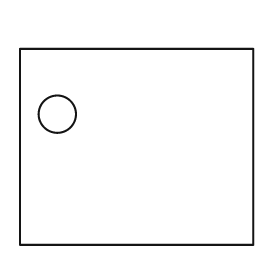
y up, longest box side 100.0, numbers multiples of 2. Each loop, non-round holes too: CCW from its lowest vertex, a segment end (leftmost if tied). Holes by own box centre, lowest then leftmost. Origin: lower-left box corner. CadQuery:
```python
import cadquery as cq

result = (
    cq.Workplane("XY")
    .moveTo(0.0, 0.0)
    .lineTo(100.0, 0.0)
    .lineTo(100.0, 84.0)
    .lineTo(0.0, 84.0)
    .close()
    .moveTo(16.0, 56.0)
    .circle(8.0)
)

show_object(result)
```